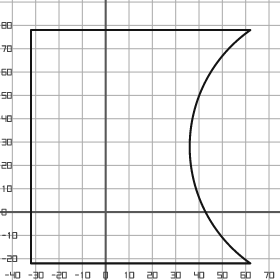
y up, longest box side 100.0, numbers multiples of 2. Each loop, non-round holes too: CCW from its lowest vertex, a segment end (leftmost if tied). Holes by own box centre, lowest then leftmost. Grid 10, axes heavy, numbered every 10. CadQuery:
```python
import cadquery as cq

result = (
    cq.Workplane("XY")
    .moveTo(-32.0, -22.0)
    .lineTo(62.0, -22.0)
    .threePointArc((36.0, 28.0), (62.0, 78.0))
    .lineTo(-32.0, 78.0)
    .close()
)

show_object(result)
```